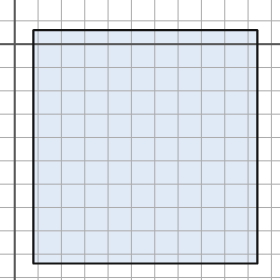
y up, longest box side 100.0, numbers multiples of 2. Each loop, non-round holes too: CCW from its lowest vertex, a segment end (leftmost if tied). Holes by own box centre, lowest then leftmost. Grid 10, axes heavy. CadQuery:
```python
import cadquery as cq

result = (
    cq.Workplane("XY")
    .moveTo(8.0, -94.0)
    .lineTo(104.0, -94.0)
    .lineTo(104.0, 6.0)
    .lineTo(8.0, 6.0)
    .close()
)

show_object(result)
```